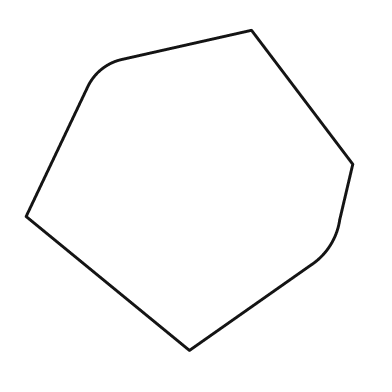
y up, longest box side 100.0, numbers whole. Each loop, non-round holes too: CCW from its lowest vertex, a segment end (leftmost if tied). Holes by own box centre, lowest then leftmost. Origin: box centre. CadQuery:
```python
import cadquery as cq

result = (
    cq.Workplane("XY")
    .moveTo(0.0, -49.0)
    .lineTo(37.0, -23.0)
    .threePointArc((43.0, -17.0), (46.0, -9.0))
    .lineTo(50.0, 8.0)
    .lineTo(19.0, 49.0)
    .lineTo(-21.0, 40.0)
    .threePointArc((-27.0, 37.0), (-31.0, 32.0))
    .lineTo(-50.0, -8.0)
    .close()
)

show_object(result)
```